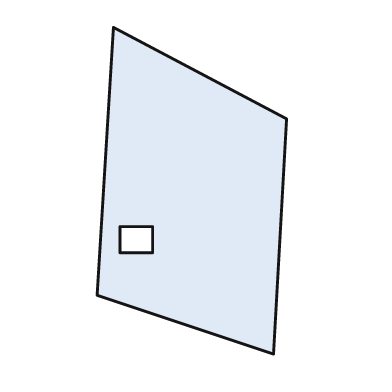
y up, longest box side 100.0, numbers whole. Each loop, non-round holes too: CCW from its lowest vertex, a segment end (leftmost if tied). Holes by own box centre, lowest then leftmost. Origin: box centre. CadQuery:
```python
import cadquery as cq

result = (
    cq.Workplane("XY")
    .moveTo(25.0, -50.0)
    .lineTo(29.0, 22.0)
    .lineTo(-24.0, 50.0)
    .lineTo(-29.0, -32.0)
    .close()
    .moveTo(-22.0, -19.0)
    .lineTo(-12.0, -19.0)
    .lineTo(-12.0, -11.0)
    .lineTo(-22.0, -11.0)
    .close()
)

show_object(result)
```